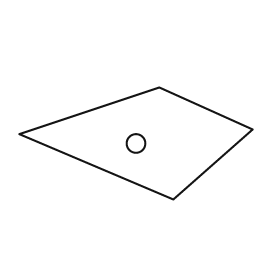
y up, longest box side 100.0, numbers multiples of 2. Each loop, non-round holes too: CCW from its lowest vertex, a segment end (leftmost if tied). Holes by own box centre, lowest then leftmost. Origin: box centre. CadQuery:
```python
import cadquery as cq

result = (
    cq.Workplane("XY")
    .moveTo(16.0, -24.0)
    .lineTo(50.0, 6.0)
    .lineTo(10.0, 24.0)
    .lineTo(-50.0, 4.0)
    .close()
    .moveTo(0.0, 0.0)
    .circle(4.0)
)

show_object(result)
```